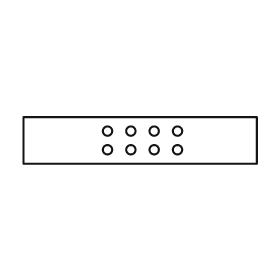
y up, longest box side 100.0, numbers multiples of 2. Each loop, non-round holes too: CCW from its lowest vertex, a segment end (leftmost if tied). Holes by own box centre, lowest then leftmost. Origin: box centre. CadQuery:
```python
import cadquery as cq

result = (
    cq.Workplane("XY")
    .moveTo(-50.0, -10.0)
    .lineTo(50.0, -10.0)
    .lineTo(50.0, 10.0)
    .lineTo(-50.0, 10.0)
    .close()
    .moveTo(-14.0, -4.0)
    .circle(2.0)
    .moveTo(-4.0, -4.0)
    .circle(2.0)
    .moveTo(6.0, -4.0)
    .circle(2.0)
    .moveTo(16.0, -4.0)
    .circle(2.0)
    .moveTo(-14.0, 4.0)
    .circle(2.0)
    .moveTo(-4.0, 4.0)
    .circle(2.0)
    .moveTo(6.0, 4.0)
    .circle(2.0)
    .moveTo(16.0, 4.0)
    .circle(2.0)
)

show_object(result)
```